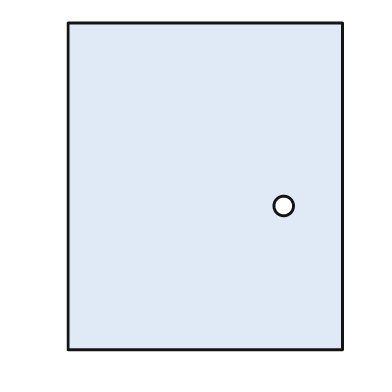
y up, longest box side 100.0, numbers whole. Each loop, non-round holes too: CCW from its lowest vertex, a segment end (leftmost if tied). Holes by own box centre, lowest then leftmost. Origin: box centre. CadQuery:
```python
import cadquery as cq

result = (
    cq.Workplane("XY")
    .moveTo(-42.0, -50.0)
    .lineTo(42.0, -50.0)
    .lineTo(42.0, 50.0)
    .lineTo(-42.0, 50.0)
    .close()
    .moveTo(24.0, -6.0)
    .circle(3.0)
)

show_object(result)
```